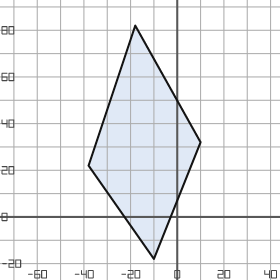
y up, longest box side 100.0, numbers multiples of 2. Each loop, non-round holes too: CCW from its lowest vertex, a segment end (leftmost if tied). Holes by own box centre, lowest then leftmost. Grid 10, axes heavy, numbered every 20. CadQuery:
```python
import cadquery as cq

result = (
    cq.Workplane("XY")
    .moveTo(-10.0, -18.0)
    .lineTo(10.0, 32.0)
    .lineTo(-18.0, 82.0)
    .lineTo(-38.0, 22.0)
    .close()
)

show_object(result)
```